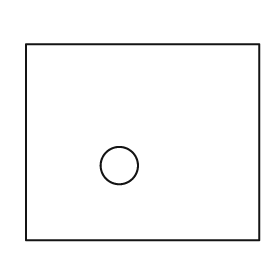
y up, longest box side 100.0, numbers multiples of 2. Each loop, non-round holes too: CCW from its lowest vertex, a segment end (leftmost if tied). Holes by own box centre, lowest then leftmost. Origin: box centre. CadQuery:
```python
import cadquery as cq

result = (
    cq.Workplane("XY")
    .moveTo(-50.0, -42.0)
    .lineTo(50.0, -42.0)
    .lineTo(50.0, 42.0)
    .lineTo(-50.0, 42.0)
    .close()
    .moveTo(-10.0, -10.0)
    .circle(8.0)
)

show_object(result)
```